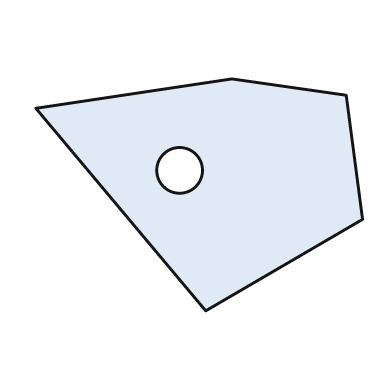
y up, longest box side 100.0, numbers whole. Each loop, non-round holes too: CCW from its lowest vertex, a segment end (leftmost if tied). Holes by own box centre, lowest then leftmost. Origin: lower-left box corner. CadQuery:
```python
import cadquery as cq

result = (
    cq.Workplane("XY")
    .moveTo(52.0, 0.0)
    .lineTo(100.0, 28.0)
    .lineTo(95.0, 66.0)
    .lineTo(60.0, 71.0)
    .lineTo(0.0, 62.0)
    .close()
    .moveTo(44.0, 43.0)
    .circle(7.0)
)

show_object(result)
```